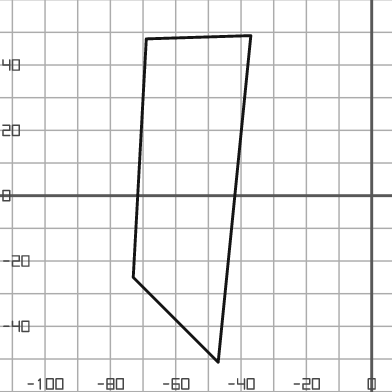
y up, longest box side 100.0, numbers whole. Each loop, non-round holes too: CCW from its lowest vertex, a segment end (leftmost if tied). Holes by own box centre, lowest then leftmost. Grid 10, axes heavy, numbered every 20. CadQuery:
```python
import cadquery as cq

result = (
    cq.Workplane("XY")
    .moveTo(-47.0, -51.0)
    .lineTo(-37.0, 49.0)
    .lineTo(-69.0, 48.0)
    .lineTo(-73.0, -25.0)
    .close()
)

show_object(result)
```